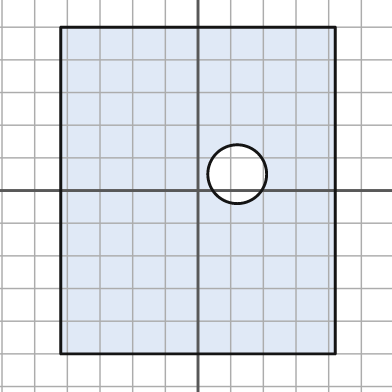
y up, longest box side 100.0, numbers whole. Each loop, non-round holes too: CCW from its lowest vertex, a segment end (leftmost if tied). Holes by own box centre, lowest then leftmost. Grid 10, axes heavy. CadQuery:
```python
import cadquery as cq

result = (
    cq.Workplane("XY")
    .moveTo(-42.0, -50.0)
    .lineTo(42.0, -50.0)
    .lineTo(42.0, 50.0)
    .lineTo(-42.0, 50.0)
    .close()
    .moveTo(12.0, 5.0)
    .circle(9.0)
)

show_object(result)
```